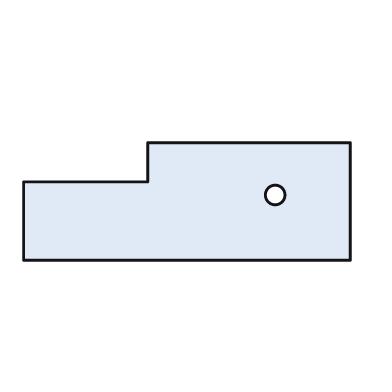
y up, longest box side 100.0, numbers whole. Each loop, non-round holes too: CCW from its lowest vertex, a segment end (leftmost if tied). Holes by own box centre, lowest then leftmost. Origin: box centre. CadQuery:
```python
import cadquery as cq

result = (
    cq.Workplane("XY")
    .moveTo(-50.0, -18.0)
    .lineTo(50.0, -18.0)
    .lineTo(50.0, 18.0)
    .lineTo(-12.0, 18.0)
    .lineTo(-12.0, 6.0)
    .lineTo(-50.0, 6.0)
    .close()
    .moveTo(27.0, 2.0)
    .circle(3.0)
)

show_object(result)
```